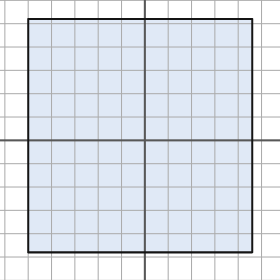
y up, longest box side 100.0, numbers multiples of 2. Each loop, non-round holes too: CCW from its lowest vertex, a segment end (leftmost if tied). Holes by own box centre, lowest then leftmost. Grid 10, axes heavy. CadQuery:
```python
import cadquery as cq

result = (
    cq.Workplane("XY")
    .moveTo(-50.0, -48.0)
    .lineTo(46.0, -48.0)
    .lineTo(46.0, 52.0)
    .lineTo(-50.0, 52.0)
    .close()
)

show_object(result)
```